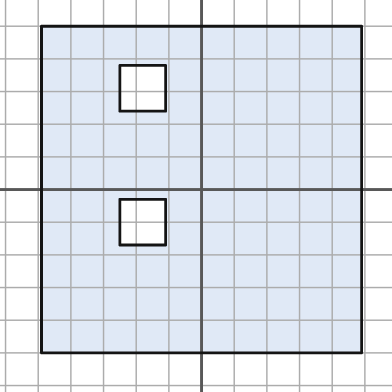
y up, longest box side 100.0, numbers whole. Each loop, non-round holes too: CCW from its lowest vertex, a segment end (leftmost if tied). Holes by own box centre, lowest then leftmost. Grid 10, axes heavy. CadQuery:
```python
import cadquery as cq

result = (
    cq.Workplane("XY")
    .moveTo(-49.0, -50.0)
    .lineTo(49.0, -50.0)
    .lineTo(49.0, 50.0)
    .lineTo(-49.0, 50.0)
    .close()
    .moveTo(-25.0, -17.0)
    .lineTo(-11.0, -17.0)
    .lineTo(-11.0, -3.0)
    .lineTo(-25.0, -3.0)
    .close()
    .moveTo(-25.0, 24.0)
    .lineTo(-11.0, 24.0)
    .lineTo(-11.0, 38.0)
    .lineTo(-25.0, 38.0)
    .close()
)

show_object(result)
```